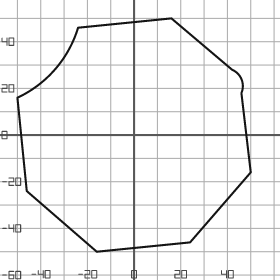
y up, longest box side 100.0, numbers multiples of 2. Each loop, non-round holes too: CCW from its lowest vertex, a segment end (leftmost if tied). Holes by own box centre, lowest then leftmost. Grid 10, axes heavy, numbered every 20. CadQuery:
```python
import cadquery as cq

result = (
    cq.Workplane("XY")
    .moveTo(-16.0, -50.0)
    .lineTo(24.0, -46.0)
    .lineTo(50.0, -16.0)
    .lineTo(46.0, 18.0)
    .threePointArc((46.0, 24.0), (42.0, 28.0))
    .lineTo(16.0, 50.0)
    .lineTo(-24.0, 46.0)
    .threePointArc((-34.0, 28.0), (-50.0, 16.0))
    .lineTo(-46.0, -24.0)
    .close()
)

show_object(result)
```